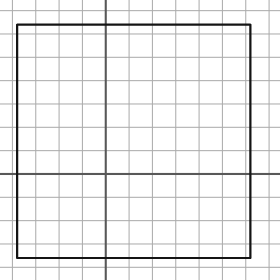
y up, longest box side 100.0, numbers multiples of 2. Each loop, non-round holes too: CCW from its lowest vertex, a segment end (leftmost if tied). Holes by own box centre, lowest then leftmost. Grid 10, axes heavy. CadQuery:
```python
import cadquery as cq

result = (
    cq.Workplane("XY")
    .moveTo(-38.0, -36.0)
    .lineTo(62.0, -36.0)
    .lineTo(62.0, 64.0)
    .lineTo(-38.0, 64.0)
    .close()
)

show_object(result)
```